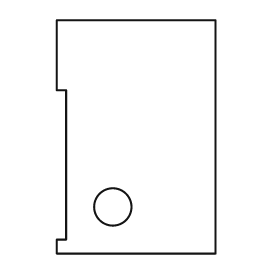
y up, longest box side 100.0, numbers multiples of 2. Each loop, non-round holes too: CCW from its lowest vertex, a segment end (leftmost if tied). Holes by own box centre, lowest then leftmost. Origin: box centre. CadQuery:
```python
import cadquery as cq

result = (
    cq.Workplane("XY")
    .moveTo(-34.0, -50.0)
    .lineTo(34.0, -50.0)
    .lineTo(34.0, 50.0)
    .lineTo(-34.0, 50.0)
    .lineTo(-34.0, 20.0)
    .lineTo(-30.0, 20.0)
    .lineTo(-30.0, -44.0)
    .lineTo(-34.0, -44.0)
    .close()
    .moveTo(-10.0, -30.0)
    .circle(8.0)
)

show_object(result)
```